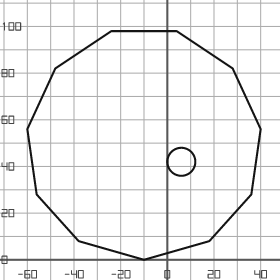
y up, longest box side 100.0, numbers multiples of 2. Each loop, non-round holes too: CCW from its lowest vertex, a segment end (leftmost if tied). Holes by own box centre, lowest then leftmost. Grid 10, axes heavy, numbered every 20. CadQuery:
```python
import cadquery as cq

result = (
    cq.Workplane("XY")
    .moveTo(-10.0, 0.0)
    .lineTo(18.0, 8.0)
    .lineTo(36.0, 28.0)
    .lineTo(40.0, 56.0)
    .lineTo(28.0, 82.0)
    .lineTo(4.0, 98.0)
    .lineTo(-24.0, 98.0)
    .lineTo(-48.0, 82.0)
    .lineTo(-60.0, 56.0)
    .lineTo(-56.0, 28.0)
    .lineTo(-38.0, 8.0)
    .close()
    .moveTo(6.0, 42.0)
    .circle(6.0)
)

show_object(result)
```